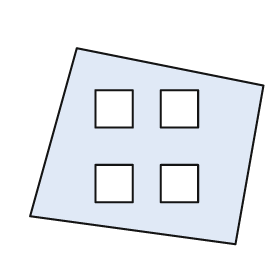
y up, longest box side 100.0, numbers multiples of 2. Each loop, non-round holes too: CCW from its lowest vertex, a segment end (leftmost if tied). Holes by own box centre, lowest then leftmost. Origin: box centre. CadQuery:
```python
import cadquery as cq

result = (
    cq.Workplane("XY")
    .moveTo(38.0, -42.0)
    .lineTo(50.0, 26.0)
    .lineTo(-30.0, 42.0)
    .lineTo(-50.0, -30.0)
    .close()
    .moveTo(-22.0, -24.0)
    .lineTo(-6.0, -24.0)
    .lineTo(-6.0, -8.0)
    .lineTo(-22.0, -8.0)
    .close()
    .moveTo(6.0, -24.0)
    .lineTo(22.0, -24.0)
    .lineTo(22.0, -8.0)
    .lineTo(6.0, -8.0)
    .close()
    .moveTo(-22.0, 8.0)
    .lineTo(-6.0, 8.0)
    .lineTo(-6.0, 24.0)
    .lineTo(-22.0, 24.0)
    .close()
    .moveTo(6.0, 8.0)
    .lineTo(22.0, 8.0)
    .lineTo(22.0, 24.0)
    .lineTo(6.0, 24.0)
    .close()
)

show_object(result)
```